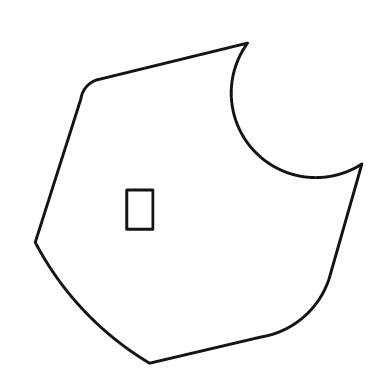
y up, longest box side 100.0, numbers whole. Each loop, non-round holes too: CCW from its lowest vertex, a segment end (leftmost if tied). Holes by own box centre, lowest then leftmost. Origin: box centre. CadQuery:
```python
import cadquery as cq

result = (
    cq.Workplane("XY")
    .moveTo(-15.0, -49.0)
    .lineTo(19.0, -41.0)
    .threePointArc((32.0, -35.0), (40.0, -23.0))
    .lineTo(50.0, 12.0)
    .threePointArc((17.0, 16.0), (15.0, 49.0))
    .lineTo(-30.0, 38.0)
    .threePointArc((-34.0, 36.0), (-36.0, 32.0))
    .lineTo(-50.0, -12.0)
    .threePointArc((-35.0, -33.0), (-15.0, -49.0))
    .close()
    .moveTo(-22.0, -8.0)
    .lineTo(-14.0, -8.0)
    .lineTo(-14.0, 4.0)
    .lineTo(-22.0, 4.0)
    .close()
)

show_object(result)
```